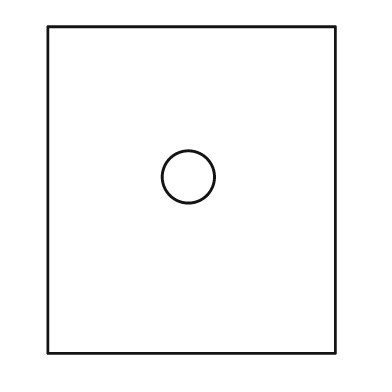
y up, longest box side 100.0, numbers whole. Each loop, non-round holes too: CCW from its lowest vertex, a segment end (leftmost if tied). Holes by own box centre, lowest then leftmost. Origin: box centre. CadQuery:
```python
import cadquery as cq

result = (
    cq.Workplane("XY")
    .moveTo(-44.0, -50.0)
    .lineTo(44.0, -50.0)
    .lineTo(44.0, 50.0)
    .lineTo(-44.0, 50.0)
    .close()
    .moveTo(-1.0, 4.0)
    .circle(8.0)
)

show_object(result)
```